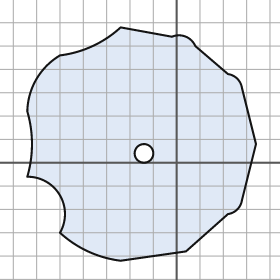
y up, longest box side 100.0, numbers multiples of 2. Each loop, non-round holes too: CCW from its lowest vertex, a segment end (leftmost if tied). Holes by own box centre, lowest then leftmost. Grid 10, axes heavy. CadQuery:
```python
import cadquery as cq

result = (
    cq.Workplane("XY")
    .moveTo(-24.0, -42.0)
    .lineTo(4.0, -38.0)
    .lineTo(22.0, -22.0)
    .threePointArc((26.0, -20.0), (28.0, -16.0))
    .lineTo(34.0, 8.0)
    .lineTo(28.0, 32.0)
    .threePointArc((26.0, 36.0), (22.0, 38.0))
    .lineTo(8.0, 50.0)
    .threePointArc((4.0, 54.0), (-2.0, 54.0))
    .lineTo(-24.0, 58.0)
    .threePointArc((-36.0, 50.0), (-50.0, 46.0))
    .threePointArc((-60.0, 36.0), (-64.0, 22.0))
    .threePointArc((-62.0, 8.0), (-64.0, -6.0))
    .threePointArc((-50.0, -14.0), (-50.0, -30.0))
    .threePointArc((-38.0, -38.0), (-24.0, -42.0))
    .close()
    .moveTo(-14.0, 4.0)
    .circle(4.0)
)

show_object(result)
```